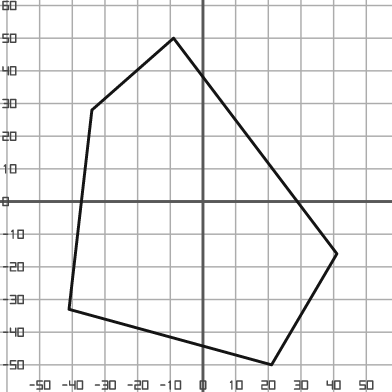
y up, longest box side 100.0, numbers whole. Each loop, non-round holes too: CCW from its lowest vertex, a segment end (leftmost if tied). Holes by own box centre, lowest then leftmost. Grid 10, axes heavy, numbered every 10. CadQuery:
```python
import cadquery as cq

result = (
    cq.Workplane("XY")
    .moveTo(21.0, -50.0)
    .lineTo(41.0, -16.0)
    .lineTo(-9.0, 50.0)
    .lineTo(-34.0, 28.0)
    .lineTo(-41.0, -33.0)
    .close()
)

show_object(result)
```